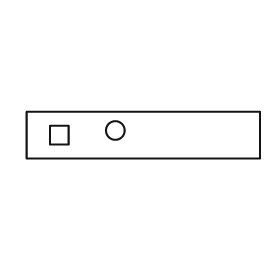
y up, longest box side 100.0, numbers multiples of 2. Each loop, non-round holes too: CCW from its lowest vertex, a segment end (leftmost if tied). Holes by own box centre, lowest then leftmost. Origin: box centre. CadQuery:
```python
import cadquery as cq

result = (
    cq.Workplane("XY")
    .moveTo(-50.0, -10.0)
    .lineTo(50.0, -10.0)
    .lineTo(50.0, 10.0)
    .lineTo(-50.0, 10.0)
    .close()
    .moveTo(-40.0, -4.0)
    .lineTo(-32.0, -4.0)
    .lineTo(-32.0, 4.0)
    .lineTo(-40.0, 4.0)
    .close()
    .moveTo(-12.0, 2.0)
    .circle(4.0)
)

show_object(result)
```